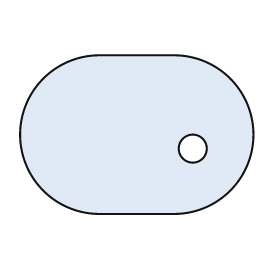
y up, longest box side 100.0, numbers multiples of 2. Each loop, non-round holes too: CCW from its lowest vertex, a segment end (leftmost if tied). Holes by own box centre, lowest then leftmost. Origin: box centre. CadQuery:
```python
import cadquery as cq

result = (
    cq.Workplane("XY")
    .moveTo(-16.0, -34.0)
    .lineTo(16.0, -34.0)
    .threePointArc((50.0, 0.0), (16.0, 34.0))
    .lineTo(-16.0, 34.0)
    .threePointArc((-50.0, 0.0), (-16.0, -34.0))
    .close()
    .moveTo(24.0, -6.0)
    .circle(6.0)
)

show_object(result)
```